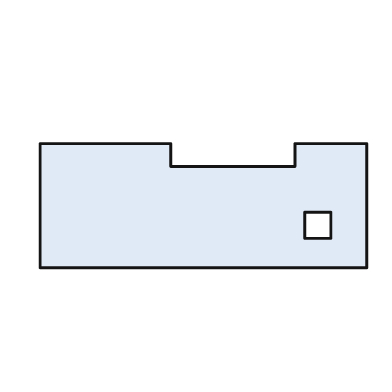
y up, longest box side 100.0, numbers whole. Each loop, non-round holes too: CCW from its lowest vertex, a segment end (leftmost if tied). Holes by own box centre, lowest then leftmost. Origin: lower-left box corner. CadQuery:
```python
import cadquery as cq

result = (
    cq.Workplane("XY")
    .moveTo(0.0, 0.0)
    .lineTo(100.0, 0.0)
    .lineTo(100.0, 38.0)
    .lineTo(78.0, 38.0)
    .lineTo(78.0, 31.0)
    .lineTo(40.0, 31.0)
    .lineTo(40.0, 38.0)
    .lineTo(0.0, 38.0)
    .close()
    .moveTo(81.0, 9.0)
    .lineTo(89.0, 9.0)
    .lineTo(89.0, 17.0)
    .lineTo(81.0, 17.0)
    .close()
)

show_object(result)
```